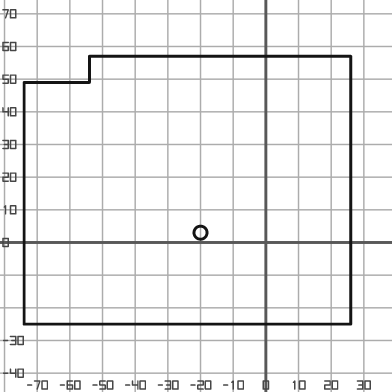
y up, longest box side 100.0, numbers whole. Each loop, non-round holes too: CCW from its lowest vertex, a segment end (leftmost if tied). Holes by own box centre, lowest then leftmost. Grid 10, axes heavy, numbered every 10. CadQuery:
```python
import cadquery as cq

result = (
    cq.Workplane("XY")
    .moveTo(-74.0, -25.0)
    .lineTo(26.0, -25.0)
    .lineTo(26.0, 57.0)
    .lineTo(-54.0, 57.0)
    .lineTo(-54.0, 49.0)
    .lineTo(-74.0, 49.0)
    .close()
    .moveTo(-20.0, 3.0)
    .circle(2.0)
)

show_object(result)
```